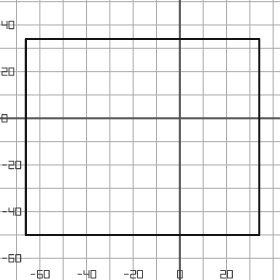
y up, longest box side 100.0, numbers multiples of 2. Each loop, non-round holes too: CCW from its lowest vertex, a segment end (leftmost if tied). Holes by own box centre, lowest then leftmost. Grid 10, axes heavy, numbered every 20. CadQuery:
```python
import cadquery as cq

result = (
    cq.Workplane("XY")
    .moveTo(-66.0, -50.0)
    .lineTo(34.0, -50.0)
    .lineTo(34.0, 34.0)
    .lineTo(-66.0, 34.0)
    .close()
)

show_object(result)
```